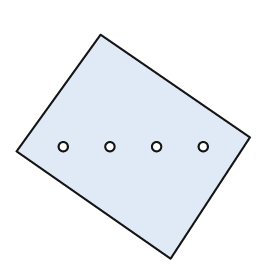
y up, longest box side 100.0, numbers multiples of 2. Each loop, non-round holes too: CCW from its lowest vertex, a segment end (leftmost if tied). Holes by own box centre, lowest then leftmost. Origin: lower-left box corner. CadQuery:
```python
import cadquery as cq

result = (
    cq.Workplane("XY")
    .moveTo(66.0, 0.0)
    .lineTo(100.0, 52.0)
    .lineTo(36.0, 96.0)
    .lineTo(0.0, 46.0)
    .close()
    .moveTo(20.0, 48.0)
    .circle(2.0)
    .moveTo(40.0, 48.0)
    .circle(2.0)
    .moveTo(60.0, 48.0)
    .circle(2.0)
    .moveTo(80.0, 48.0)
    .circle(2.0)
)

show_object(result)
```